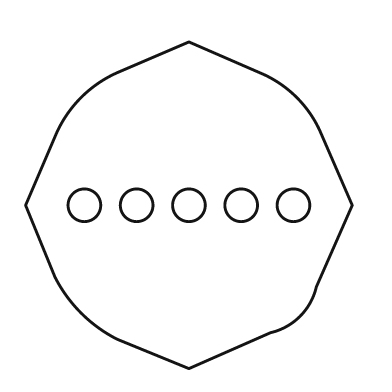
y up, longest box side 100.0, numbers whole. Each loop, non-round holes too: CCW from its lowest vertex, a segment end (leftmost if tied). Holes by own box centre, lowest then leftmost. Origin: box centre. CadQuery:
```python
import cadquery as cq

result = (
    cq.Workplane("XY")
    .moveTo(0.0, -50.0)
    .lineTo(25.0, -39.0)
    .threePointArc((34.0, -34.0), (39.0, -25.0))
    .lineTo(50.0, 0.0)
    .lineTo(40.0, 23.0)
    .threePointArc((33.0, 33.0), (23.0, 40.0))
    .lineTo(0.0, 50.0)
    .lineTo(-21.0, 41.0)
    .threePointArc((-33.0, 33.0), (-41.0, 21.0))
    .lineTo(-50.0, 0.0)
    .lineTo(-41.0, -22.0)
    .threePointArc((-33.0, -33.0), (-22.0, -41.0))
    .close()
    .moveTo(-32.0, 0.0)
    .circle(5.0)
    .moveTo(-16.0, 0.0)
    .circle(5.0)
    .moveTo(0.0, 0.0)
    .circle(5.0)
    .moveTo(16.0, 0.0)
    .circle(5.0)
    .moveTo(32.0, 0.0)
    .circle(5.0)
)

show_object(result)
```